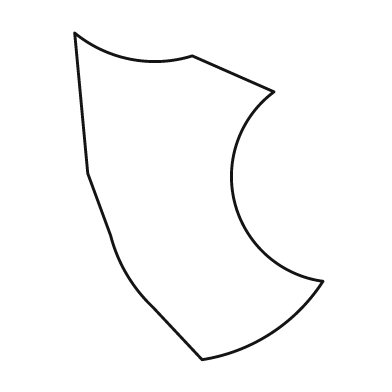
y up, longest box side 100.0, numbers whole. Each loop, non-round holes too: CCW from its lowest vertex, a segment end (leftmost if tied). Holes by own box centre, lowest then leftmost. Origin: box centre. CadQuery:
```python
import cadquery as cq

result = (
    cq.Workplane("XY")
    .moveTo(1.0, -50.0)
    .threePointArc((22.0, -42.0), (38.0, -26.0))
    .threePointArc((11.0, -2.0), (23.0, 32.0))
    .lineTo(-2.0, 43.0)
    .threePointArc((-21.0, 42.0), (-38.0, 50.0))
    .lineTo(-34.0, 7.0)
    .lineTo(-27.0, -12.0)
    .threePointArc((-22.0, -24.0), (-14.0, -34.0))
    .close()
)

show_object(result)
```